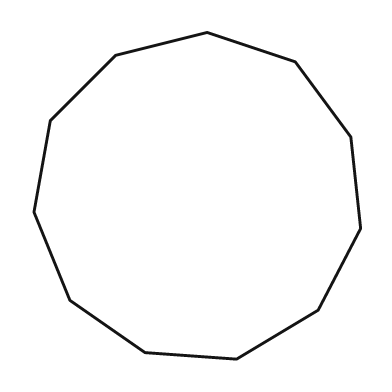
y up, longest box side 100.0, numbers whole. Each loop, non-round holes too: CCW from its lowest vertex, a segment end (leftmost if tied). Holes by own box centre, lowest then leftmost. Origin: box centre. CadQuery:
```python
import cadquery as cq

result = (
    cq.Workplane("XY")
    .moveTo(12.0, -50.0)
    .lineTo(37.0, -35.0)
    .lineTo(50.0, -10.0)
    .lineTo(47.0, 18.0)
    .lineTo(30.0, 41.0)
    .lineTo(3.0, 50.0)
    .lineTo(-25.0, 43.0)
    .lineTo(-45.0, 23.0)
    .lineTo(-50.0, -5.0)
    .lineTo(-39.0, -32.0)
    .lineTo(-16.0, -48.0)
    .close()
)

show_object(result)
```